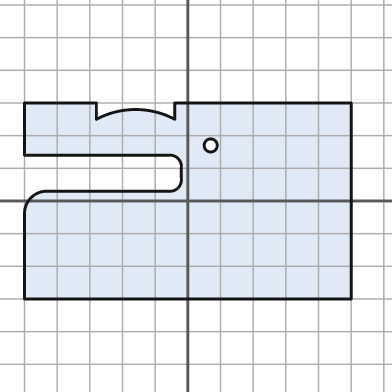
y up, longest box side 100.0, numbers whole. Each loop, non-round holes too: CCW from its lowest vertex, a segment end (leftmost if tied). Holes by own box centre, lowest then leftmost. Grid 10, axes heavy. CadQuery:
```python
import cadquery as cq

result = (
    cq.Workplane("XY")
    .moveTo(-50.0, -30.0)
    .lineTo(50.0, -30.0)
    .lineTo(50.0, 30.0)
    .lineTo(-4.0, 30.0)
    .lineTo(-4.0, 25.0)
    .threePointArc((-16.0, 28.0), (-28.0, 25.0))
    .lineTo(-28.0, 30.0)
    .lineTo(-50.0, 30.0)
    .lineTo(-50.0, 14.0)
    .lineTo(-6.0, 14.0)
    .threePointArc((-3.0, 13.0), (-2.0, 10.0))
    .lineTo(-2.0, 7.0)
    .threePointArc((-3.0, 4.0), (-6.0, 3.0))
    .lineTo(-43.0, 3.0)
    .threePointArc((-48.0, 1.0), (-50.0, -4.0))
    .close()
    .moveTo(7.0, 17.0)
    .circle(2.0)
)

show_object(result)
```